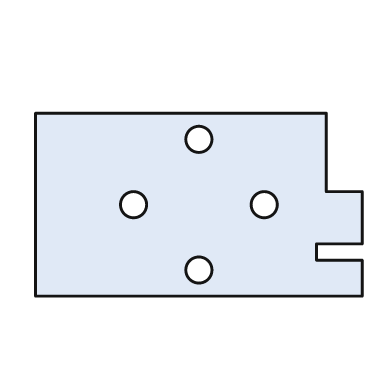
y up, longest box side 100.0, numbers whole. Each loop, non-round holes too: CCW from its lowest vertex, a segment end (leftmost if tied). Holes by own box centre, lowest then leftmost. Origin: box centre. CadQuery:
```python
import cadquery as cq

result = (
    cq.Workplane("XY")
    .moveTo(-50.0, -28.0)
    .lineTo(50.0, -28.0)
    .lineTo(50.0, -17.0)
    .lineTo(36.0, -17.0)
    .lineTo(36.0, -12.0)
    .lineTo(50.0, -12.0)
    .lineTo(50.0, 4.0)
    .lineTo(39.0, 4.0)
    .lineTo(39.0, 28.0)
    .lineTo(-50.0, 28.0)
    .close()
    .moveTo(0.0, -20.0)
    .circle(4.0)
    .moveTo(-20.0, 0.0)
    .circle(4.0)
    .moveTo(20.0, 0.0)
    .circle(4.0)
    .moveTo(0.0, 20.0)
    .circle(4.0)
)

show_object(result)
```